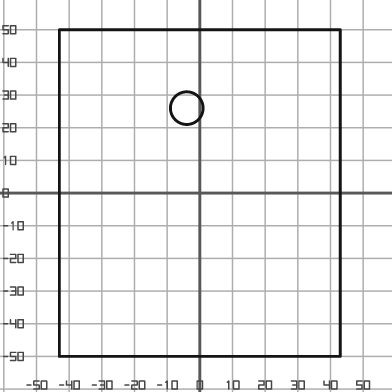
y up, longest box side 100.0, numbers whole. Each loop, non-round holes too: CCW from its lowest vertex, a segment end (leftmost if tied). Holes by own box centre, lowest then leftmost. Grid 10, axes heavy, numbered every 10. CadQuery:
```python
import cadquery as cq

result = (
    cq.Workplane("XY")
    .moveTo(-43.0, -50.0)
    .lineTo(43.0, -50.0)
    .lineTo(43.0, 50.0)
    .lineTo(-43.0, 50.0)
    .close()
    .moveTo(-4.0, 26.0)
    .circle(5.0)
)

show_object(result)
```